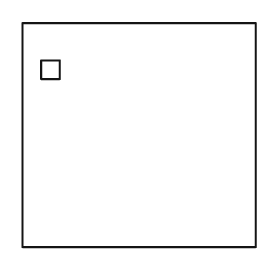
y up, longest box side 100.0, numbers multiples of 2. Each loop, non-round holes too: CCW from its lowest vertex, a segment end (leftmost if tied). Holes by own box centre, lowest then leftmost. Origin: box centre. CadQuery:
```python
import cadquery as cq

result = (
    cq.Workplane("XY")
    .moveTo(-50.0, -48.0)
    .lineTo(50.0, -48.0)
    .lineTo(50.0, 48.0)
    .lineTo(-50.0, 48.0)
    .close()
    .moveTo(-42.0, 24.0)
    .lineTo(-34.0, 24.0)
    .lineTo(-34.0, 32.0)
    .lineTo(-42.0, 32.0)
    .close()
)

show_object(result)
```